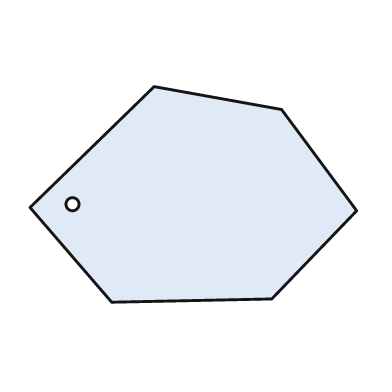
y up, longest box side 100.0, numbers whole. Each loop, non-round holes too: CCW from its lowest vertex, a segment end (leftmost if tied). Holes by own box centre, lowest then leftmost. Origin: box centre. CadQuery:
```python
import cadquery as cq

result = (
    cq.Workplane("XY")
    .moveTo(-25.0, -33.0)
    .lineTo(24.0, -32.0)
    .lineTo(50.0, -5.0)
    .lineTo(27.0, 26.0)
    .lineTo(-12.0, 33.0)
    .lineTo(-50.0, -4.0)
    .close()
    .moveTo(-37.0, -3.0)
    .circle(2.0)
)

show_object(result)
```